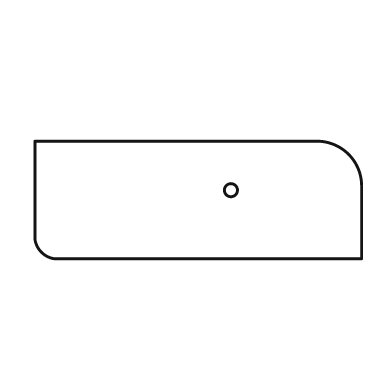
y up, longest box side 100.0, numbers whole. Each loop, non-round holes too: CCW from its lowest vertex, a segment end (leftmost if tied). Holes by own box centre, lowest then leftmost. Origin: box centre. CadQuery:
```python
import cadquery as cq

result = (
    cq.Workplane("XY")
    .moveTo(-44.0, -18.0)
    .lineTo(50.0, -18.0)
    .lineTo(50.0, 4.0)
    .threePointArc((46.0, 14.0), (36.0, 18.0))
    .lineTo(-50.0, 18.0)
    .lineTo(-50.0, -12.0)
    .threePointArc((-48.0, -16.0), (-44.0, -18.0))
    .close()
    .moveTo(10.0, 3.0)
    .circle(2.0)
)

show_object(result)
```